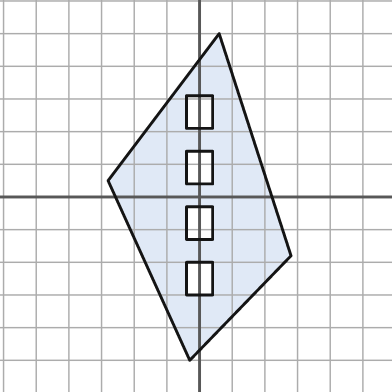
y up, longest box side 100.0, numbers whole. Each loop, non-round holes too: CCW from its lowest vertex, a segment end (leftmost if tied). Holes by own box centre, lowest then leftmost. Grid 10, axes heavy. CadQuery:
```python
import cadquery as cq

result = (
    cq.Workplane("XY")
    .moveTo(-3.0, -50.0)
    .lineTo(28.0, -18.0)
    .lineTo(6.0, 50.0)
    .lineTo(-28.0, 5.0)
    .close()
    .moveTo(-4.0, -30.0)
    .lineTo(4.0, -30.0)
    .lineTo(4.0, -20.0)
    .lineTo(-4.0, -20.0)
    .close()
    .moveTo(-4.0, -13.0)
    .lineTo(4.0, -13.0)
    .lineTo(4.0, -3.0)
    .lineTo(-4.0, -3.0)
    .close()
    .moveTo(-4.0, 4.0)
    .lineTo(4.0, 4.0)
    .lineTo(4.0, 14.0)
    .lineTo(-4.0, 14.0)
    .close()
    .moveTo(-4.0, 21.0)
    .lineTo(4.0, 21.0)
    .lineTo(4.0, 31.0)
    .lineTo(-4.0, 31.0)
    .close()
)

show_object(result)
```